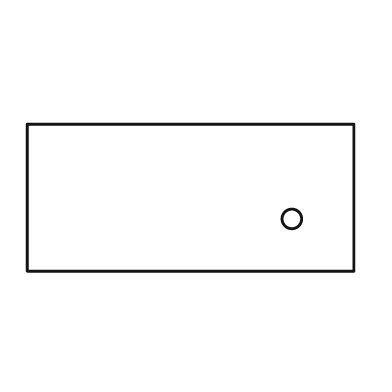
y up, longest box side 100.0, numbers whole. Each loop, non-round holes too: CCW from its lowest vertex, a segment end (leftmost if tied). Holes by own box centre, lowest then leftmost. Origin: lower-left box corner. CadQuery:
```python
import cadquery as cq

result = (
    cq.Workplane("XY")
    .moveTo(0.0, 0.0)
    .lineTo(100.0, 0.0)
    .lineTo(100.0, 45.0)
    .lineTo(0.0, 45.0)
    .close()
    .moveTo(81.0, 16.0)
    .circle(3.0)
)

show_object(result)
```